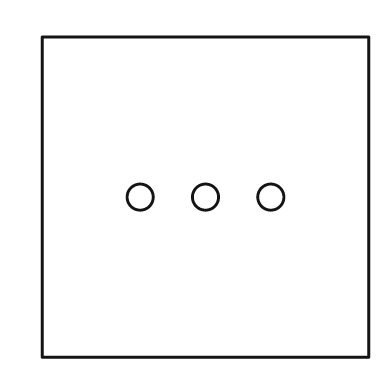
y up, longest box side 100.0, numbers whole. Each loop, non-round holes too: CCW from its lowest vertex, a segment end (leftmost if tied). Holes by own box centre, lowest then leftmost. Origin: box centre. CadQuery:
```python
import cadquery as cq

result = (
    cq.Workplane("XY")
    .moveTo(-50.0, -49.0)
    .lineTo(50.0, -49.0)
    .lineTo(50.0, 49.0)
    .lineTo(-50.0, 49.0)
    .close()
    .moveTo(-20.0, 0.0)
    .circle(4.0)
    .moveTo(0.0, 0.0)
    .circle(4.0)
    .moveTo(20.0, 0.0)
    .circle(4.0)
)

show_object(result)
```